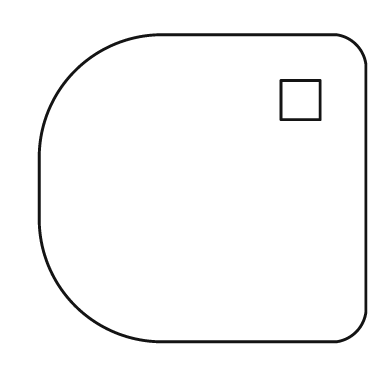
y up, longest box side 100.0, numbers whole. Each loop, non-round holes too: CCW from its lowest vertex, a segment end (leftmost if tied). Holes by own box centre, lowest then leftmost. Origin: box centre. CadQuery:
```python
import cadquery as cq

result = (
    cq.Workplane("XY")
    .moveTo(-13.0, -47.0)
    .lineTo(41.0, -47.0)
    .threePointArc((47.0, -44.0), (50.0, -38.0))
    .lineTo(50.0, 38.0)
    .threePointArc((47.0, 44.0), (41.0, 47.0))
    .lineTo(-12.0, 47.0)
    .threePointArc((-39.0, 36.0), (-50.0, 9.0))
    .lineTo(-50.0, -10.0)
    .threePointArc((-39.0, -36.0), (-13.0, -47.0))
    .close()
    .moveTo(24.0, 21.0)
    .lineTo(36.0, 21.0)
    .lineTo(36.0, 33.0)
    .lineTo(24.0, 33.0)
    .close()
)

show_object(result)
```